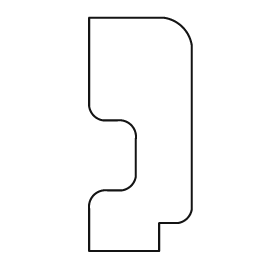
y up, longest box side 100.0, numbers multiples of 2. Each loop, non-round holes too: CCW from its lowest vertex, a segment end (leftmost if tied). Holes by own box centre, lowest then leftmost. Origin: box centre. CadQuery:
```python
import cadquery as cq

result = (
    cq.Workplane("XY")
    .moveTo(-22.0, -50.0)
    .lineTo(8.0, -50.0)
    .lineTo(8.0, -38.0)
    .lineTo(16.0, -38.0)
    .threePointArc((20.0, -36.0), (22.0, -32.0))
    .lineTo(22.0, 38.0)
    .threePointArc((18.0, 46.0), (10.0, 50.0))
    .lineTo(-22.0, 50.0)
    .lineTo(-22.0, 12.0)
    .threePointArc((-20.0, 8.0), (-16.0, 6.0))
    .lineTo(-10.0, 6.0)
    .threePointArc((-4.0, 4.0), (-2.0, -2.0))
    .lineTo(-2.0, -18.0)
    .threePointArc((-4.0, -22.0), (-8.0, -24.0))
    .lineTo(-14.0, -24.0)
    .threePointArc((-20.0, -26.0), (-22.0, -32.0))
    .close()
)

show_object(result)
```